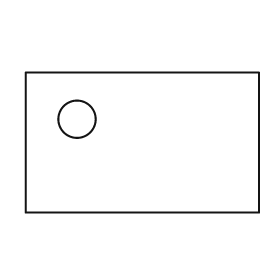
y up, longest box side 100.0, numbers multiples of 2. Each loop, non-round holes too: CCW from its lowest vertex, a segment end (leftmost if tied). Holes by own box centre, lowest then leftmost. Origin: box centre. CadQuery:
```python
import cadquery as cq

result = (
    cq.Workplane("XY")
    .moveTo(-50.0, -30.0)
    .lineTo(50.0, -30.0)
    .lineTo(50.0, 30.0)
    .lineTo(-50.0, 30.0)
    .close()
    .moveTo(-28.0, 10.0)
    .circle(8.0)
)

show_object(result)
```